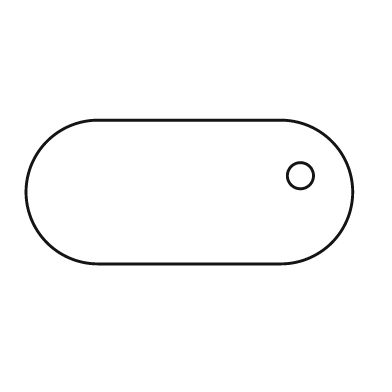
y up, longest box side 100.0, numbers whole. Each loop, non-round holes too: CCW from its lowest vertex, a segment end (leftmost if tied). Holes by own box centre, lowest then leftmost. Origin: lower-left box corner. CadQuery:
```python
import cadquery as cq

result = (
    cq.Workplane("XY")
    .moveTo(22.0, 0.0)
    .lineTo(78.0, 0.0)
    .threePointArc((100.0, 22.0), (78.0, 44.0))
    .lineTo(22.0, 44.0)
    .threePointArc((0.0, 22.0), (22.0, 0.0))
    .close()
    .moveTo(84.0, 27.0)
    .circle(4.0)
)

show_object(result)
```